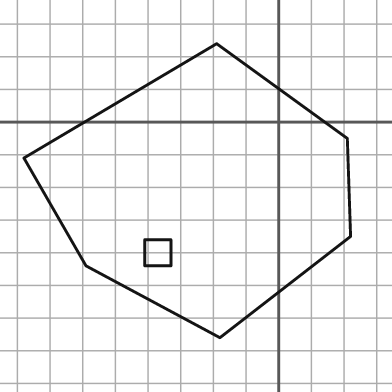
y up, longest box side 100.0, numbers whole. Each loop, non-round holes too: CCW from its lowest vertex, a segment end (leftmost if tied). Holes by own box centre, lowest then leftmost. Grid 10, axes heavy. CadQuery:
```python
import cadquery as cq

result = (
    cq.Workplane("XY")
    .moveTo(-18.0, -66.0)
    .lineTo(22.0, -35.0)
    .lineTo(21.0, -5.0)
    .lineTo(-19.0, 24.0)
    .lineTo(-78.0, -11.0)
    .lineTo(-59.0, -44.0)
    .close()
    .moveTo(-41.0, -44.0)
    .lineTo(-33.0, -44.0)
    .lineTo(-33.0, -36.0)
    .lineTo(-41.0, -36.0)
    .close()
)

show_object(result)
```